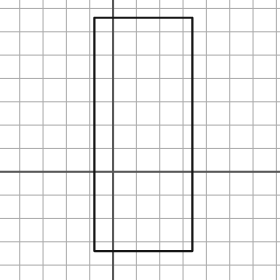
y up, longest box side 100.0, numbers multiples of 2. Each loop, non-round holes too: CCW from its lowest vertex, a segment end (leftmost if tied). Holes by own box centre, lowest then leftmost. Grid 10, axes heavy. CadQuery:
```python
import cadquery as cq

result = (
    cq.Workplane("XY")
    .moveTo(-8.0, -34.0)
    .lineTo(34.0, -34.0)
    .lineTo(34.0, 66.0)
    .lineTo(-8.0, 66.0)
    .close()
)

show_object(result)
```